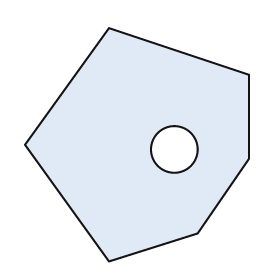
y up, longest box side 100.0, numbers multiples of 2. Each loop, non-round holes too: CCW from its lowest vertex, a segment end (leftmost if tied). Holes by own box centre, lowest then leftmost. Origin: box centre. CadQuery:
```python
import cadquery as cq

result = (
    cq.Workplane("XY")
    .moveTo(-12.0, -50.0)
    .lineTo(26.0, -38.0)
    .lineTo(48.0, -6.0)
    .lineTo(48.0, 30.0)
    .lineTo(-12.0, 50.0)
    .lineTo(-48.0, 0.0)
    .close()
    .moveTo(16.0, -2.0)
    .circle(10.0)
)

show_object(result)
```